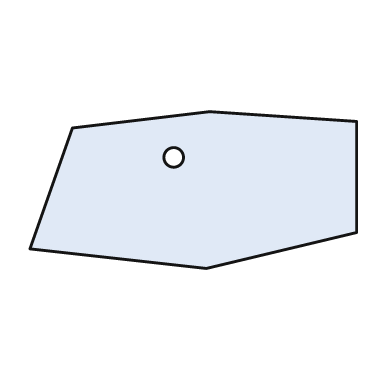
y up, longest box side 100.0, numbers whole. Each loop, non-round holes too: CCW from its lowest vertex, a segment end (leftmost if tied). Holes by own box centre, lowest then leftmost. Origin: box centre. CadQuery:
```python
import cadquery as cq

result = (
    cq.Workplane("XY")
    .moveTo(4.0, -24.0)
    .lineTo(50.0, -13.0)
    .lineTo(50.0, 21.0)
    .lineTo(5.0, 24.0)
    .lineTo(-37.0, 19.0)
    .lineTo(-50.0, -18.0)
    .close()
    .moveTo(-6.0, 10.0)
    .circle(3.0)
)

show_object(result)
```